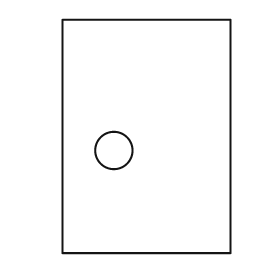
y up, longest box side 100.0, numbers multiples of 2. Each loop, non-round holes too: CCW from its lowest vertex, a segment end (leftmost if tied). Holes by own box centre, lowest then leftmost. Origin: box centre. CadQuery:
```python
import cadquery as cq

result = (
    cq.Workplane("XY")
    .moveTo(-36.0, -50.0)
    .lineTo(36.0, -50.0)
    .lineTo(36.0, 50.0)
    .lineTo(-36.0, 50.0)
    .close()
    .moveTo(-14.0, -6.0)
    .circle(8.0)
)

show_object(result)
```